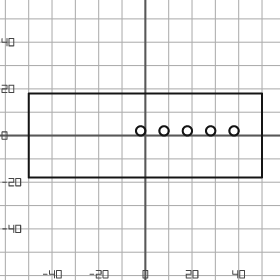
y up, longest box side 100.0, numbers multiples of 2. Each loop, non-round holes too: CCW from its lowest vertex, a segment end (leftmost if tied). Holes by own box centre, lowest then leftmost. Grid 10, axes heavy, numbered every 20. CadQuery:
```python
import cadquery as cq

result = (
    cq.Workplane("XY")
    .moveTo(-50.0, -18.0)
    .lineTo(50.0, -18.0)
    .lineTo(50.0, 18.0)
    .lineTo(-50.0, 18.0)
    .close()
    .moveTo(-2.0, 2.0)
    .circle(2.0)
    .moveTo(8.0, 2.0)
    .circle(2.0)
    .moveTo(18.0, 2.0)
    .circle(2.0)
    .moveTo(28.0, 2.0)
    .circle(2.0)
    .moveTo(38.0, 2.0)
    .circle(2.0)
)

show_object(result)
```